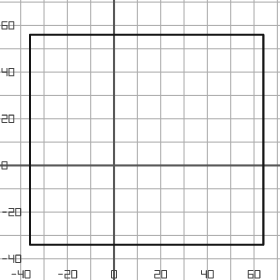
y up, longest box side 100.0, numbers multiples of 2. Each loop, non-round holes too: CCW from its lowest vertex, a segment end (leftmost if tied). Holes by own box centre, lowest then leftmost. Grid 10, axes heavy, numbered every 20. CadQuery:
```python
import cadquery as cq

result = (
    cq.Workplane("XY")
    .moveTo(-36.0, -34.0)
    .lineTo(64.0, -34.0)
    .lineTo(64.0, 56.0)
    .lineTo(-36.0, 56.0)
    .close()
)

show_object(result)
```